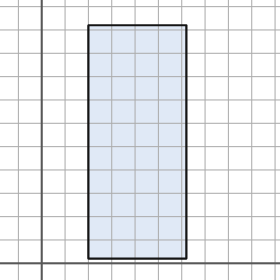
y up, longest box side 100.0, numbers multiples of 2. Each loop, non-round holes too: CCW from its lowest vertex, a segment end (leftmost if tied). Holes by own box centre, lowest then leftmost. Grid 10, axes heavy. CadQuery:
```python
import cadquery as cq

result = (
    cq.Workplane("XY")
    .moveTo(20.0, 2.0)
    .lineTo(62.0, 2.0)
    .lineTo(62.0, 102.0)
    .lineTo(20.0, 102.0)
    .close()
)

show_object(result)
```